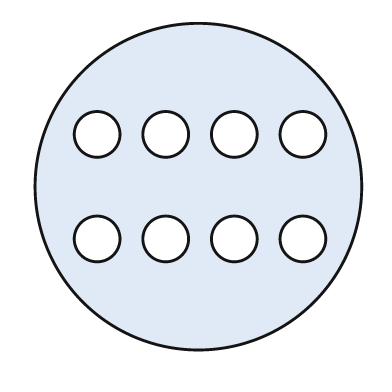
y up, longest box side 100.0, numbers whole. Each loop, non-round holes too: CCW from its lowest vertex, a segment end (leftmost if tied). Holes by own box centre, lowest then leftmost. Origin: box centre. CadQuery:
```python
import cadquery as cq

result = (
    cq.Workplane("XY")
    .moveTo(0.0, 0.0)
    .circle(50.0)
    .moveTo(-31.0, -16.0)
    .circle(7.0)
    .moveTo(-10.0, -16.0)
    .circle(7.0)
    .moveTo(11.0, -16.0)
    .circle(7.0)
    .moveTo(32.0, -16.0)
    .circle(7.0)
    .moveTo(-31.0, 16.0)
    .circle(7.0)
    .moveTo(-10.0, 16.0)
    .circle(7.0)
    .moveTo(11.0, 16.0)
    .circle(7.0)
    .moveTo(32.0, 16.0)
    .circle(7.0)
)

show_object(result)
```